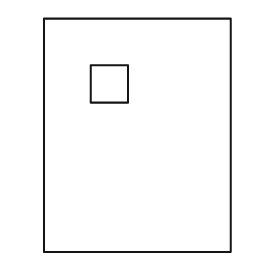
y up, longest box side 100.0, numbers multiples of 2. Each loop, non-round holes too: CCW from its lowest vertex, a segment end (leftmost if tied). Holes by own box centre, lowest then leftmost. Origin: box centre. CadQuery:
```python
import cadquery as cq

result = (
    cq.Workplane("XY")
    .moveTo(-40.0, -50.0)
    .lineTo(40.0, -50.0)
    .lineTo(40.0, 50.0)
    .lineTo(-40.0, 50.0)
    .close()
    .moveTo(-20.0, 14.0)
    .lineTo(-4.0, 14.0)
    .lineTo(-4.0, 30.0)
    .lineTo(-20.0, 30.0)
    .close()
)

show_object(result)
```